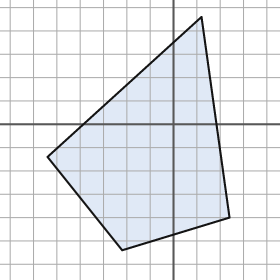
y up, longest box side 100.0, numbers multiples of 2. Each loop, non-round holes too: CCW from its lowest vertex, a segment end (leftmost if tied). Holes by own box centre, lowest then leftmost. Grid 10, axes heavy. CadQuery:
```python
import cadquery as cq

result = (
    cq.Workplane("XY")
    .moveTo(-22.0, -54.0)
    .lineTo(24.0, -40.0)
    .lineTo(12.0, 46.0)
    .lineTo(-54.0, -14.0)
    .close()
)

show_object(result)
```